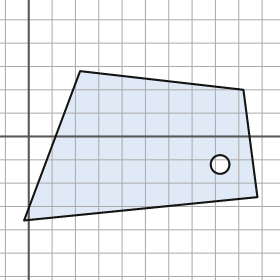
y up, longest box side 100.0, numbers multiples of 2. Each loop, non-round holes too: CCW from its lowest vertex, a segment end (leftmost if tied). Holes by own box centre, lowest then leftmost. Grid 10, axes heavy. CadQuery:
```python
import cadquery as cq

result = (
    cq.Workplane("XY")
    .moveTo(-2.0, -36.0)
    .lineTo(98.0, -26.0)
    .lineTo(92.0, 20.0)
    .lineTo(22.0, 28.0)
    .close()
    .moveTo(82.0, -12.0)
    .circle(4.0)
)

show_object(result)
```